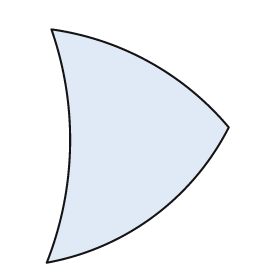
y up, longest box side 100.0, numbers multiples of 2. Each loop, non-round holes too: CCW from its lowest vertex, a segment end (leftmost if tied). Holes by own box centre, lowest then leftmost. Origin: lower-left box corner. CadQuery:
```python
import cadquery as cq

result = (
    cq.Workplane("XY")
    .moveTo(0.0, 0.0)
    .threePointArc((46.0, 20.0), (78.0, 58.0))
    .threePointArc((44.0, 86.0), (2.0, 100.0))
    .threePointArc((10.0, 50.0), (0.0, 0.0))
    .close()
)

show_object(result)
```